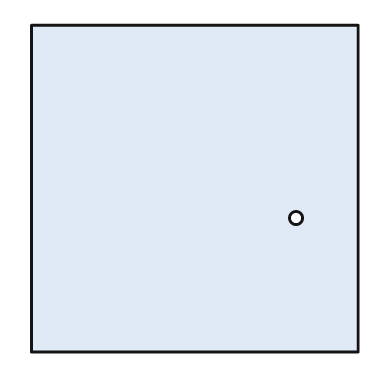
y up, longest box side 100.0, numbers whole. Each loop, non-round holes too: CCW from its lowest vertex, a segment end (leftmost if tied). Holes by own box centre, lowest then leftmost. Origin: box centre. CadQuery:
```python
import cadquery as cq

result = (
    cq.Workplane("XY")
    .moveTo(-50.0, -50.0)
    .lineTo(50.0, -50.0)
    .lineTo(50.0, 50.0)
    .lineTo(-50.0, 50.0)
    .close()
    .moveTo(31.0, -9.0)
    .circle(2.0)
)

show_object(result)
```